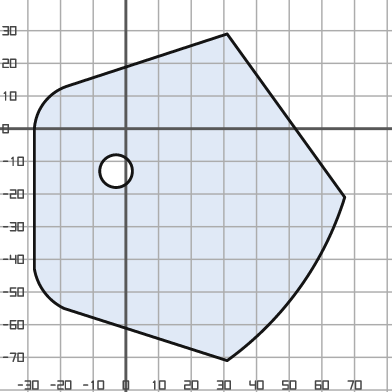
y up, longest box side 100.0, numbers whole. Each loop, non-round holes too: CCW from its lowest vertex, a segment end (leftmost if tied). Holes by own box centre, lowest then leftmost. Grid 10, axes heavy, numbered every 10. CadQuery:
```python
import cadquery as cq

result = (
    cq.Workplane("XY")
    .moveTo(31.0, -71.0)
    .threePointArc((53.0, -49.0), (67.0, -21.0))
    .lineTo(31.0, 29.0)
    .lineTo(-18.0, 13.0)
    .threePointArc((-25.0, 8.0), (-28.0, 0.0))
    .lineTo(-28.0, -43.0)
    .threePointArc((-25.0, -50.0), (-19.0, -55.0))
    .close()
    .moveTo(-3.0, -13.0)
    .circle(5.0)
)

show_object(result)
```